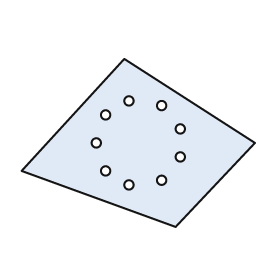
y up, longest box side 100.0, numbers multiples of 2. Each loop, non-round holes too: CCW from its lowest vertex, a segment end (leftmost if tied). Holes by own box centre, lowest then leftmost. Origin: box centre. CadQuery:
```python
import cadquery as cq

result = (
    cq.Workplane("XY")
    .moveTo(16.0, -36.0)
    .lineTo(50.0, 0.0)
    .lineTo(-6.0, 36.0)
    .lineTo(-50.0, -12.0)
    .close()
    .moveTo(-4.0, -18.0)
    .circle(2.0)
    .moveTo(10.0, -16.0)
    .circle(2.0)
    .moveTo(-14.0, -12.0)
    .circle(2.0)
    .moveTo(18.0, -6.0)
    .circle(2.0)
    .moveTo(-18.0, 0.0)
    .circle(2.0)
    .moveTo(18.0, 6.0)
    .circle(2.0)
    .moveTo(-14.0, 12.0)
    .circle(2.0)
    .moveTo(10.0, 16.0)
    .circle(2.0)
    .moveTo(-4.0, 18.0)
    .circle(2.0)
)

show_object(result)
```